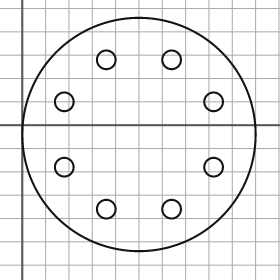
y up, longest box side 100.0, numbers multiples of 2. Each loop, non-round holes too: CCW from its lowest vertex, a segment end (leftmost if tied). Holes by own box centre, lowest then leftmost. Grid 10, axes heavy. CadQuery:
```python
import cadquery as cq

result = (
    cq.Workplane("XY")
    .moveTo(50.0, -4.0)
    .circle(50.0)
    .moveTo(36.0, -36.0)
    .circle(4.0)
    .moveTo(64.0, -36.0)
    .circle(4.0)
    .moveTo(18.0, -18.0)
    .circle(4.0)
    .moveTo(82.0, -18.0)
    .circle(4.0)
    .moveTo(18.0, 10.0)
    .circle(4.0)
    .moveTo(82.0, 10.0)
    .circle(4.0)
    .moveTo(36.0, 28.0)
    .circle(4.0)
    .moveTo(64.0, 28.0)
    .circle(4.0)
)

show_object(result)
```